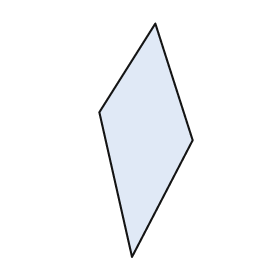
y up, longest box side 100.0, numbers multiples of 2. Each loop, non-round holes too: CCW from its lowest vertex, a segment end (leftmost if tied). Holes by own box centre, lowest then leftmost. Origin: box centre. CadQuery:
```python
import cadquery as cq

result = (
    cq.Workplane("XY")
    .moveTo(-6.0, -50.0)
    .lineTo(20.0, 0.0)
    .lineTo(4.0, 50.0)
    .lineTo(-20.0, 12.0)
    .close()
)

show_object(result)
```